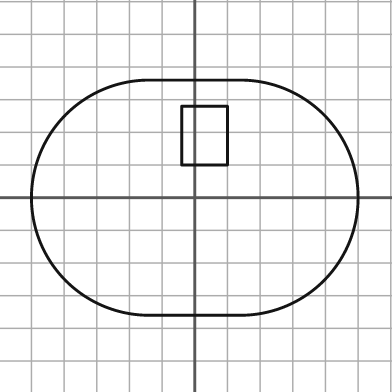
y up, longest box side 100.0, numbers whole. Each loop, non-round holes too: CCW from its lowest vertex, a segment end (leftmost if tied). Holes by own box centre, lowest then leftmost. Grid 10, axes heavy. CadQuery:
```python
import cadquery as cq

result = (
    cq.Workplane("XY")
    .moveTo(-14.0, -36.0)
    .lineTo(14.0, -36.0)
    .threePointArc((50.0, 0.0), (14.0, 36.0))
    .lineTo(-14.0, 36.0)
    .threePointArc((-50.0, 0.0), (-14.0, -36.0))
    .close()
    .moveTo(-4.0, 10.0)
    .lineTo(10.0, 10.0)
    .lineTo(10.0, 28.0)
    .lineTo(-4.0, 28.0)
    .close()
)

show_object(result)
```